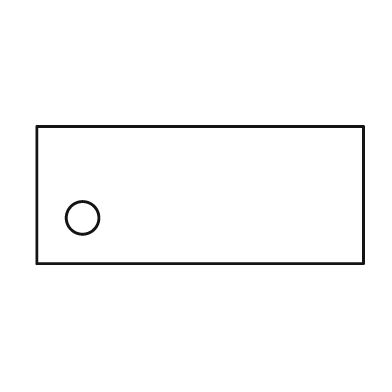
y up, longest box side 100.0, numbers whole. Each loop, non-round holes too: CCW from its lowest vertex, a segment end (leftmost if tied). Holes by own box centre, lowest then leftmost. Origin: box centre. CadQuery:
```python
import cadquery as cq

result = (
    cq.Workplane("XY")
    .moveTo(-50.0, -21.0)
    .lineTo(50.0, -21.0)
    .lineTo(50.0, 21.0)
    .lineTo(-50.0, 21.0)
    .close()
    .moveTo(-36.0, -7.0)
    .circle(5.0)
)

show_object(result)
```